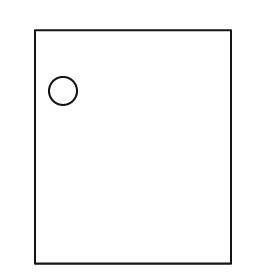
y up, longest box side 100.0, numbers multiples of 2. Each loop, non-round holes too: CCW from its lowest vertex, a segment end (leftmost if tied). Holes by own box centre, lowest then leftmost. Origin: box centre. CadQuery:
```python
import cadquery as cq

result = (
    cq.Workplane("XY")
    .moveTo(-42.0, -50.0)
    .lineTo(42.0, -50.0)
    .lineTo(42.0, 50.0)
    .lineTo(-42.0, 50.0)
    .close()
    .moveTo(-30.0, 24.0)
    .circle(6.0)
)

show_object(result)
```